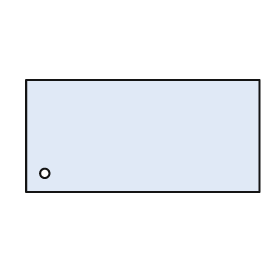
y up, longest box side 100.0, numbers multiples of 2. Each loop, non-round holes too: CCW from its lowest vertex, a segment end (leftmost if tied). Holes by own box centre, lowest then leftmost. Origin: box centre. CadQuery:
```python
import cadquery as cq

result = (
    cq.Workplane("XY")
    .moveTo(-50.0, -24.0)
    .lineTo(50.0, -24.0)
    .lineTo(50.0, 24.0)
    .lineTo(-50.0, 24.0)
    .close()
    .moveTo(-42.0, -16.0)
    .circle(2.0)
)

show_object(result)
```